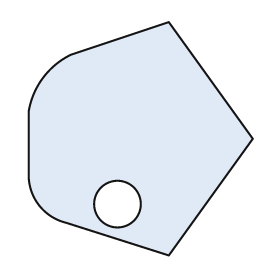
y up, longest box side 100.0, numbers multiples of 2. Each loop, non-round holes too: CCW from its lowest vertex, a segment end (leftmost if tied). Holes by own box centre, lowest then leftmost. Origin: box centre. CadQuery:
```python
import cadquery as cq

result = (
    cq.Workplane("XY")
    .moveTo(12.0, -50.0)
    .lineTo(48.0, 0.0)
    .lineTo(12.0, 50.0)
    .lineTo(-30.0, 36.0)
    .threePointArc((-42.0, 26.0), (-48.0, 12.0))
    .lineTo(-48.0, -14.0)
    .threePointArc((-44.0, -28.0), (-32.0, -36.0))
    .close()
    .moveTo(-10.0, -28.0)
    .circle(10.0)
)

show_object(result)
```